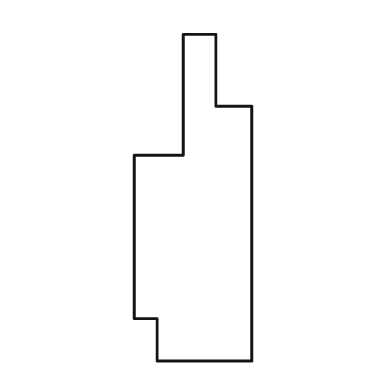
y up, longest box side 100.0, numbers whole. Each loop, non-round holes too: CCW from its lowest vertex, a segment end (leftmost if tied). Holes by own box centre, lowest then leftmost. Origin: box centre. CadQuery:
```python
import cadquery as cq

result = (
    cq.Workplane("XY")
    .moveTo(-11.0, -50.0)
    .lineTo(18.0, -50.0)
    .lineTo(18.0, 28.0)
    .lineTo(7.0, 28.0)
    .lineTo(7.0, 50.0)
    .lineTo(-3.0, 50.0)
    .lineTo(-3.0, 13.0)
    .lineTo(-18.0, 13.0)
    .lineTo(-18.0, -37.0)
    .lineTo(-11.0, -37.0)
    .close()
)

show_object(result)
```